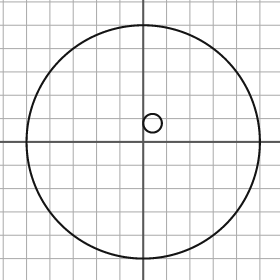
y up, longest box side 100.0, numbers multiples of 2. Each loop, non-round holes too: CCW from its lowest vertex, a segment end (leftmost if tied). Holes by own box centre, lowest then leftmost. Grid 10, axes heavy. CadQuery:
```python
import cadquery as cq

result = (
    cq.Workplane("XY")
    .moveTo(0.0, 0.0)
    .circle(50.0)
    .moveTo(4.0, 8.0)
    .circle(4.0)
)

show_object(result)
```